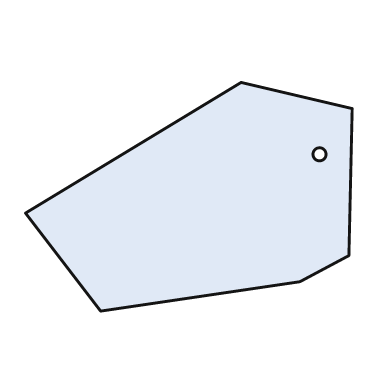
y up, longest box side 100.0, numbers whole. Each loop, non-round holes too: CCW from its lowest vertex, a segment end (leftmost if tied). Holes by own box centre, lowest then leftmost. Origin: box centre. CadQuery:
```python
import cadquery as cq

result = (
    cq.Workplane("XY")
    .moveTo(-27.0, -35.0)
    .lineTo(34.0, -26.0)
    .lineTo(49.0, -18.0)
    .lineTo(50.0, 27.0)
    .lineTo(16.0, 35.0)
    .lineTo(-50.0, -5.0)
    .close()
    .moveTo(40.0, 13.0)
    .circle(2.0)
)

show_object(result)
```